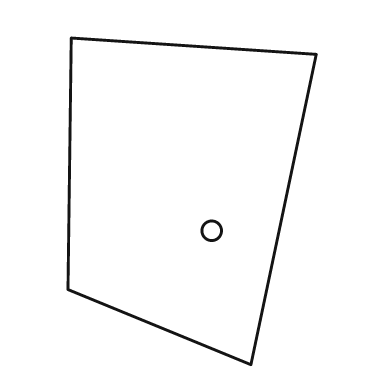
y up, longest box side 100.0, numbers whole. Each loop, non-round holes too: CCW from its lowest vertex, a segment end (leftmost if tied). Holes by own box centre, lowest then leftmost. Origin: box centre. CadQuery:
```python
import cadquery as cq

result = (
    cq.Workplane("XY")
    .moveTo(18.0, -50.0)
    .lineTo(38.0, 45.0)
    .lineTo(-37.0, 50.0)
    .lineTo(-38.0, -27.0)
    .close()
    .moveTo(6.0, -9.0)
    .circle(3.0)
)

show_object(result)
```